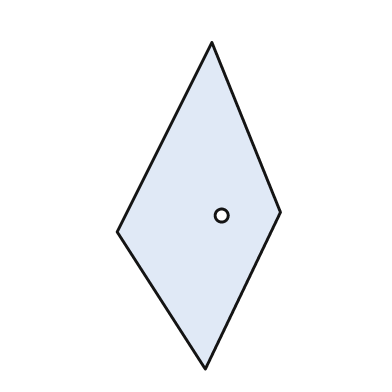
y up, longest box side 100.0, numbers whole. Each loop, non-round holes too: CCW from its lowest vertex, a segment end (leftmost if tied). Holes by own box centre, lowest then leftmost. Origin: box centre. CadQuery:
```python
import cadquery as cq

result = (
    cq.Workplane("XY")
    .moveTo(2.0, -50.0)
    .lineTo(25.0, -2.0)
    .lineTo(4.0, 50.0)
    .lineTo(-25.0, -8.0)
    .close()
    .moveTo(7.0, -3.0)
    .circle(2.0)
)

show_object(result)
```